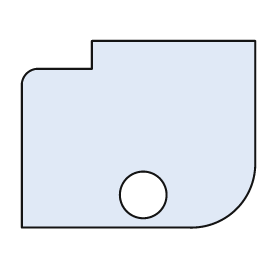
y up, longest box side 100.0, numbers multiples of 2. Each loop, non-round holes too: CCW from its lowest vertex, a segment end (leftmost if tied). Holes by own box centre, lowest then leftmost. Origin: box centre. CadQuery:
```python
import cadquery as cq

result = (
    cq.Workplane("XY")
    .moveTo(-50.0, -40.0)
    .lineTo(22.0, -40.0)
    .threePointArc((42.0, -32.0), (50.0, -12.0))
    .lineTo(50.0, 40.0)
    .lineTo(-20.0, 40.0)
    .lineTo(-20.0, 28.0)
    .lineTo(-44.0, 28.0)
    .threePointArc((-48.0, 26.0), (-50.0, 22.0))
    .close()
    .moveTo(2.0, -26.0)
    .circle(10.0)
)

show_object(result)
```